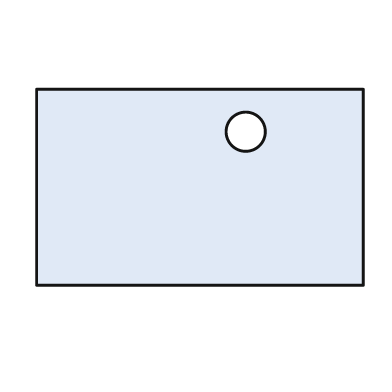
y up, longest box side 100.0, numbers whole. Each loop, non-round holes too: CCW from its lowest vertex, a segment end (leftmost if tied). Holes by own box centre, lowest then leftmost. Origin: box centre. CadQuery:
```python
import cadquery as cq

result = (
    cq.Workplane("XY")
    .moveTo(-50.0, -30.0)
    .lineTo(50.0, -30.0)
    .lineTo(50.0, 30.0)
    .lineTo(-50.0, 30.0)
    .close()
    .moveTo(14.0, 17.0)
    .circle(6.0)
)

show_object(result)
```